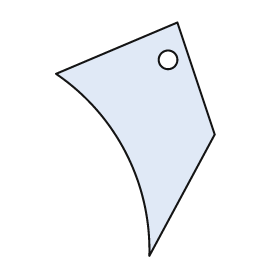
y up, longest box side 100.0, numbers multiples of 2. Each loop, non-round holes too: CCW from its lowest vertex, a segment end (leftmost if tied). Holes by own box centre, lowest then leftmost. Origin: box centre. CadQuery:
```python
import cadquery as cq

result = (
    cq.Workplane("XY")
    .moveTo(6.0, -50.0)
    .lineTo(34.0, 2.0)
    .lineTo(18.0, 50.0)
    .lineTo(-34.0, 28.0)
    .threePointArc((-4.0, -6.0), (6.0, -50.0))
    .close()
    .moveTo(14.0, 34.0)
    .circle(4.0)
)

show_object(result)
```